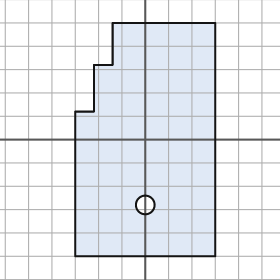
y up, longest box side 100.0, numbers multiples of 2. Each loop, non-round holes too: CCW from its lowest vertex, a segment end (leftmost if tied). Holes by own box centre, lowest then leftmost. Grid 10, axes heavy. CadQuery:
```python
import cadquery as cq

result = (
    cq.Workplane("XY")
    .moveTo(-30.0, -50.0)
    .lineTo(30.0, -50.0)
    .lineTo(30.0, 50.0)
    .lineTo(-14.0, 50.0)
    .lineTo(-14.0, 32.0)
    .lineTo(-22.0, 32.0)
    .lineTo(-22.0, 12.0)
    .lineTo(-30.0, 12.0)
    .close()
    .moveTo(0.0, -28.0)
    .circle(4.0)
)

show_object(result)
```